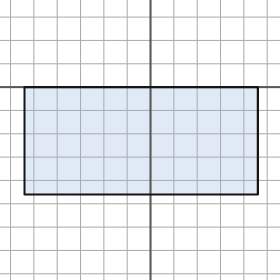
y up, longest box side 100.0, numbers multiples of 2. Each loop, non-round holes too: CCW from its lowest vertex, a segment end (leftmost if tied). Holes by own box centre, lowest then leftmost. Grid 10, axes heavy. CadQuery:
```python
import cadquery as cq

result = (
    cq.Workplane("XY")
    .moveTo(-54.0, -46.0)
    .lineTo(46.0, -46.0)
    .lineTo(46.0, 0.0)
    .lineTo(-54.0, 0.0)
    .close()
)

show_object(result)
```